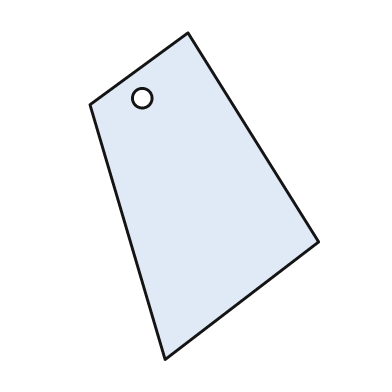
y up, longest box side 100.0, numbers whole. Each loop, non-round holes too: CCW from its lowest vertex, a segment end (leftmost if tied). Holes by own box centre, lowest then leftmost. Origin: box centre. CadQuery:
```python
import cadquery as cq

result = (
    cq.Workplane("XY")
    .moveTo(-12.0, -50.0)
    .lineTo(35.0, -14.0)
    .lineTo(-5.0, 50.0)
    .lineTo(-35.0, 28.0)
    .close()
    .moveTo(-19.0, 30.0)
    .circle(3.0)
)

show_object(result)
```